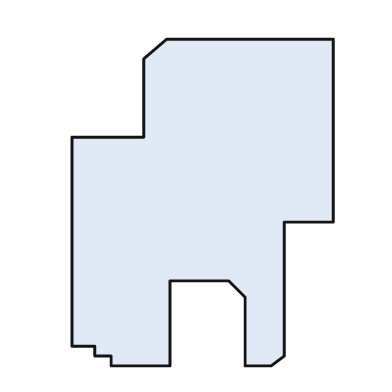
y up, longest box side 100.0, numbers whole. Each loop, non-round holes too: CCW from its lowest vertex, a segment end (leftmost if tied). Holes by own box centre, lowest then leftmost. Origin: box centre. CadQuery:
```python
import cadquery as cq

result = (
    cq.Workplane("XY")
    .moveTo(-28.0, -50.0)
    .lineTo(-10.0, -50.0)
    .lineTo(-10.0, -24.0)
    .lineTo(8.0, -24.0)
    .lineTo(13.0, -29.0)
    .lineTo(13.0, -50.0)
    .lineTo(21.0, -50.0)
    .lineTo(25.0, -47.0)
    .lineTo(25.0, -6.0)
    .lineTo(40.0, -6.0)
    .lineTo(40.0, 50.0)
    .lineTo(-11.0, 50.0)
    .lineTo(-18.0, 44.0)
    .lineTo(-18.0, 20.0)
    .lineTo(-40.0, 20.0)
    .lineTo(-40.0, -44.0)
    .lineTo(-33.0, -44.0)
    .lineTo(-33.0, -47.0)
    .lineTo(-28.0, -47.0)
    .close()
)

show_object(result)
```